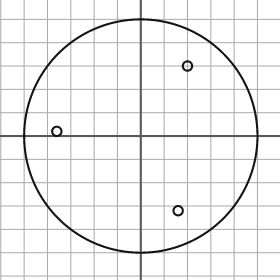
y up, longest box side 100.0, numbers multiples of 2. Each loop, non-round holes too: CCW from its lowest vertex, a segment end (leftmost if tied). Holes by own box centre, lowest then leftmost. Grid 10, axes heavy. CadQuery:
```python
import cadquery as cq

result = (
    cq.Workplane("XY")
    .moveTo(0.0, 0.0)
    .circle(50.0)
    .moveTo(16.0, -32.0)
    .circle(2.0)
    .moveTo(-36.0, 2.0)
    .circle(2.0)
    .moveTo(20.0, 30.0)
    .circle(2.0)
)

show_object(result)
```